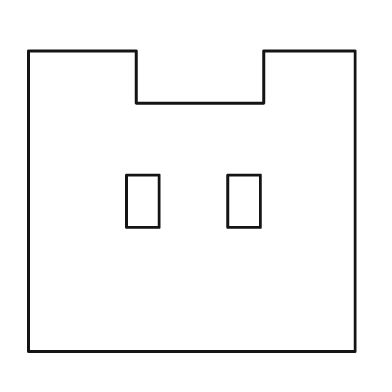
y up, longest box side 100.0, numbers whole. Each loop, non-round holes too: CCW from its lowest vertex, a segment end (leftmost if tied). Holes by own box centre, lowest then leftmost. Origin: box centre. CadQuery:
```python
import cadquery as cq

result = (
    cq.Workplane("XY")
    .moveTo(-50.0, -46.0)
    .lineTo(50.0, -46.0)
    .lineTo(50.0, 46.0)
    .lineTo(22.0, 46.0)
    .lineTo(22.0, 30.0)
    .lineTo(-17.0, 30.0)
    .lineTo(-17.0, 46.0)
    .lineTo(-50.0, 46.0)
    .close()
    .moveTo(-20.0, -8.0)
    .lineTo(-10.0, -8.0)
    .lineTo(-10.0, 8.0)
    .lineTo(-20.0, 8.0)
    .close()
    .moveTo(11.0, -8.0)
    .lineTo(21.0, -8.0)
    .lineTo(21.0, 8.0)
    .lineTo(11.0, 8.0)
    .close()
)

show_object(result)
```